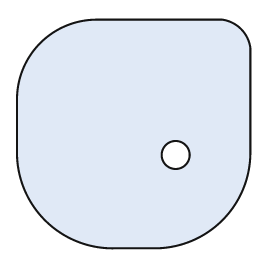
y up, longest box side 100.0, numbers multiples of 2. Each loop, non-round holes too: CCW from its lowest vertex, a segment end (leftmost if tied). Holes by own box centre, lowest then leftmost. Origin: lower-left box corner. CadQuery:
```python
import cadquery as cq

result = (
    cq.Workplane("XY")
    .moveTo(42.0, 0.0)
    .lineTo(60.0, 0.0)
    .threePointArc((88.0, 12.0), (100.0, 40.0))
    .lineTo(100.0, 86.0)
    .threePointArc((96.0, 94.0), (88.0, 98.0))
    .lineTo(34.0, 98.0)
    .threePointArc((10.0, 88.0), (0.0, 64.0))
    .lineTo(0.0, 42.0)
    .threePointArc((12.0, 12.0), (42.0, 0.0))
    .close()
    .moveTo(68.0, 40.0)
    .circle(6.0)
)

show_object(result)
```